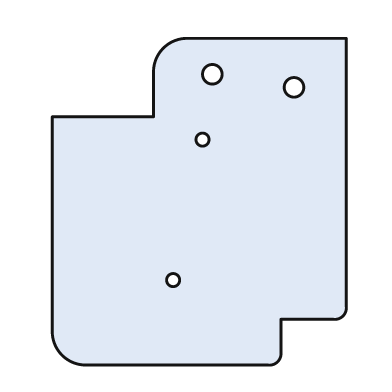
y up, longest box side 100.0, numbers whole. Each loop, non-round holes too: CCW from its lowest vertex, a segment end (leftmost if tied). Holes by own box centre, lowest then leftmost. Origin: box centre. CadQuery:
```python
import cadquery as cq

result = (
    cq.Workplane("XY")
    .moveTo(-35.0, -50.0)
    .lineTo(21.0, -50.0)
    .threePointArc((24.0, -49.0), (25.0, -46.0))
    .lineTo(25.0, -36.0)
    .lineTo(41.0, -36.0)
    .threePointArc((44.0, -35.0), (45.0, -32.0))
    .lineTo(45.0, 50.0)
    .lineTo(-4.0, 50.0)
    .threePointArc((-11.0, 47.0), (-14.0, 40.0))
    .lineTo(-14.0, 26.0)
    .lineTo(-45.0, 26.0)
    .lineTo(-45.0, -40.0)
    .threePointArc((-42.0, -47.0), (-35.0, -50.0))
    .close()
    .moveTo(-8.0, -24.0)
    .circle(2.0)
    .moveTo(1.0, 19.0)
    .circle(2.0)
    .moveTo(29.0, 35.0)
    .circle(3.0)
    .moveTo(4.0, 39.0)
    .circle(3.0)
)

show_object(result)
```